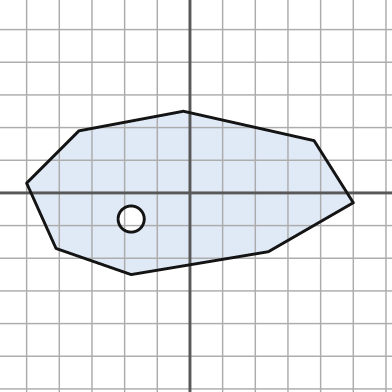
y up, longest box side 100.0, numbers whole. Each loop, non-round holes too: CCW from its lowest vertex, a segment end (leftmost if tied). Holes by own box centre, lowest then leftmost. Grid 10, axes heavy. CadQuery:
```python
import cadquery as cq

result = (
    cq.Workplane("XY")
    .moveTo(-18.0, -25.0)
    .lineTo(24.0, -18.0)
    .lineTo(50.0, -3.0)
    .lineTo(38.0, 16.0)
    .lineTo(-2.0, 25.0)
    .lineTo(-34.0, 19.0)
    .lineTo(-50.0, 3.0)
    .lineTo(-41.0, -17.0)
    .close()
    .moveTo(-18.0, -8.0)
    .circle(4.0)
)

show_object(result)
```